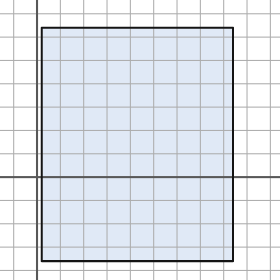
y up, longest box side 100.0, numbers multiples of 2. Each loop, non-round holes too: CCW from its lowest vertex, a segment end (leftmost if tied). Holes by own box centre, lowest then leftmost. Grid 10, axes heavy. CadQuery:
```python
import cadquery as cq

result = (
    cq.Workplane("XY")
    .moveTo(2.0, -36.0)
    .lineTo(84.0, -36.0)
    .lineTo(84.0, 64.0)
    .lineTo(2.0, 64.0)
    .close()
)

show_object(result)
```